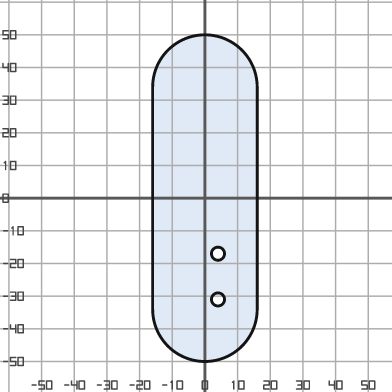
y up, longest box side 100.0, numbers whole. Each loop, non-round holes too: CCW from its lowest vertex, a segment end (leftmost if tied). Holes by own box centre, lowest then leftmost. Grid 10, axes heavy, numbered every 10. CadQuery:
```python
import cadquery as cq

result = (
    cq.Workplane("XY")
    .moveTo(-16.0, -34.0)
    .threePointArc((0.0, -50.0), (16.0, -34.0))
    .lineTo(16.0, 34.0)
    .threePointArc((0.0, 50.0), (-16.0, 34.0))
    .close()
    .moveTo(4.0, -31.0)
    .circle(2.0)
    .moveTo(4.0, -17.0)
    .circle(2.0)
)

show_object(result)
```